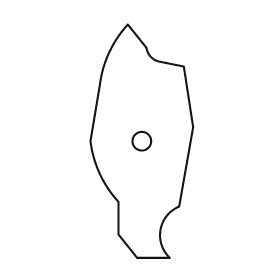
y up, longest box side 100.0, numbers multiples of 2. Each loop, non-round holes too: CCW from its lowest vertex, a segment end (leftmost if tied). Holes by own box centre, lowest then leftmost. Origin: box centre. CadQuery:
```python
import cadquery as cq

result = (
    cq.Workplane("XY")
    .moveTo(-2.0, -50.0)
    .lineTo(12.0, -50.0)
    .threePointArc((8.0, -38.0), (16.0, -28.0))
    .lineTo(22.0, 6.0)
    .lineTo(18.0, 32.0)
    .lineTo(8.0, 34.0)
    .threePointArc((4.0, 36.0), (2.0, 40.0))
    .lineTo(-6.0, 50.0)
    .threePointArc((-14.0, 38.0), (-18.0, 24.0))
    .lineTo(-22.0, 0.0)
    .threePointArc((-18.0, -14.0), (-10.0, -26.0))
    .lineTo(-10.0, -40.0)
    .close()
    .moveTo(0.0, 0.0)
    .circle(4.0)
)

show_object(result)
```